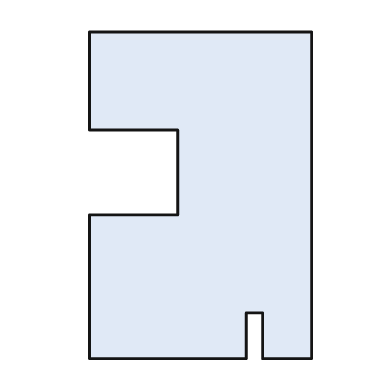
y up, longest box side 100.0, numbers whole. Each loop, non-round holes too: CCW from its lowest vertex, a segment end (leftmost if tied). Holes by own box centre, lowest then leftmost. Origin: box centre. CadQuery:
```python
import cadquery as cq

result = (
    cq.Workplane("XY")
    .moveTo(-34.0, -50.0)
    .lineTo(14.0, -50.0)
    .lineTo(14.0, -36.0)
    .lineTo(19.0, -36.0)
    .lineTo(19.0, -50.0)
    .lineTo(34.0, -50.0)
    .lineTo(34.0, 50.0)
    .lineTo(-34.0, 50.0)
    .lineTo(-34.0, 20.0)
    .lineTo(-7.0, 20.0)
    .lineTo(-7.0, -6.0)
    .lineTo(-34.0, -6.0)
    .close()
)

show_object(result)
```